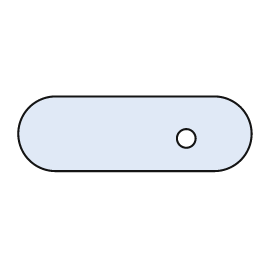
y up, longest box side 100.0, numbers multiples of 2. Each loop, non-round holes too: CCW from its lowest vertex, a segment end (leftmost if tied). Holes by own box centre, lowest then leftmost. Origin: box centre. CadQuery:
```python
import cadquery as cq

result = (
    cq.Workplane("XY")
    .moveTo(-34.0, -16.0)
    .lineTo(34.0, -16.0)
    .threePointArc((50.0, 0.0), (34.0, 16.0))
    .lineTo(-34.0, 16.0)
    .threePointArc((-50.0, 0.0), (-34.0, -16.0))
    .close()
    .moveTo(22.0, -2.0)
    .circle(4.0)
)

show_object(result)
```